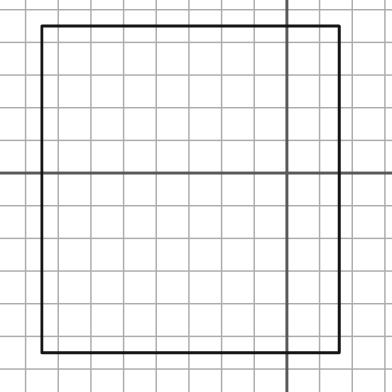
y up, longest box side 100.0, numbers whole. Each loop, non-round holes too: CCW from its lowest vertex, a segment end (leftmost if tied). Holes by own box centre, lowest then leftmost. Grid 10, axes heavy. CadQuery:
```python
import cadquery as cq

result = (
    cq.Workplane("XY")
    .moveTo(-75.0, -55.0)
    .lineTo(16.0, -55.0)
    .lineTo(16.0, 45.0)
    .lineTo(-75.0, 45.0)
    .close()
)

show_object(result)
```